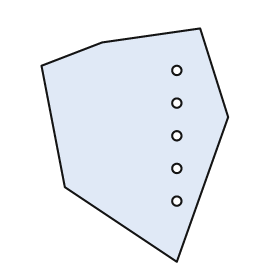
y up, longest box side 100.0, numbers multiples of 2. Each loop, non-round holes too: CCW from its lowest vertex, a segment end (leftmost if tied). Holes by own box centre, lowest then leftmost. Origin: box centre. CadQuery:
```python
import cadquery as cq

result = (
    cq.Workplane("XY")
    .moveTo(18.0, -50.0)
    .lineTo(40.0, 12.0)
    .lineTo(28.0, 50.0)
    .lineTo(-14.0, 44.0)
    .lineTo(-40.0, 34.0)
    .lineTo(-30.0, -18.0)
    .close()
    .moveTo(18.0, -24.0)
    .circle(2.0)
    .moveTo(18.0, -10.0)
    .circle(2.0)
    .moveTo(18.0, 4.0)
    .circle(2.0)
    .moveTo(18.0, 18.0)
    .circle(2.0)
    .moveTo(18.0, 32.0)
    .circle(2.0)
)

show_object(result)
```